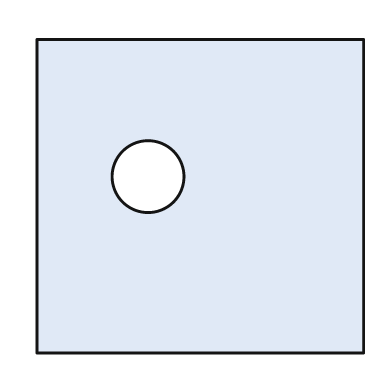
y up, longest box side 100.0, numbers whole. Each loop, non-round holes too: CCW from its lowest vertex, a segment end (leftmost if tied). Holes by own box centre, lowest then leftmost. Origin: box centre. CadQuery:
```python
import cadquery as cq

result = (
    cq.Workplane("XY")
    .moveTo(-50.0, -48.0)
    .lineTo(50.0, -48.0)
    .lineTo(50.0, 48.0)
    .lineTo(-50.0, 48.0)
    .close()
    .moveTo(-16.0, 6.0)
    .circle(11.0)
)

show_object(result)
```